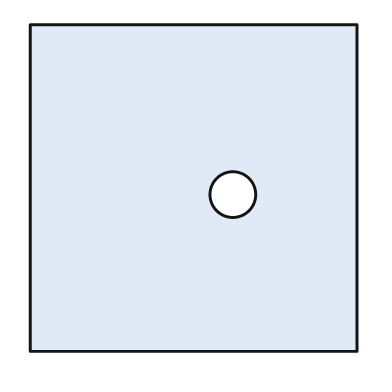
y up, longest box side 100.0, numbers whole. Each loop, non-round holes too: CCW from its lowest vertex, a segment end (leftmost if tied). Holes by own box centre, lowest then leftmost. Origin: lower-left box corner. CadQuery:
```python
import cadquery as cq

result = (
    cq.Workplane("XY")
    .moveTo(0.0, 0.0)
    .lineTo(100.0, 0.0)
    .lineTo(100.0, 100.0)
    .lineTo(0.0, 100.0)
    .close()
    .moveTo(62.0, 48.0)
    .circle(7.0)
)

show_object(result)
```